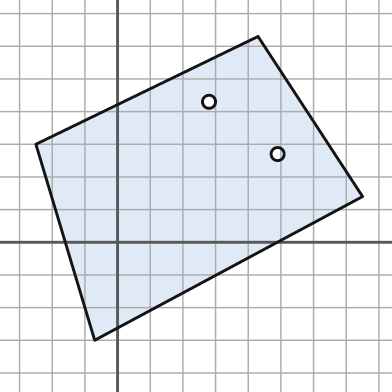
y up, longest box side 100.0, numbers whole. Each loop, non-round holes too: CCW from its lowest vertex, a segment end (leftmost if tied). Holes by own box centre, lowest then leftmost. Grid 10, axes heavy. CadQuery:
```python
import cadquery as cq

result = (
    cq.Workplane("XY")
    .moveTo(-7.0, -30.0)
    .lineTo(75.0, 14.0)
    .lineTo(43.0, 63.0)
    .lineTo(-25.0, 30.0)
    .close()
    .moveTo(49.0, 27.0)
    .circle(2.0)
    .moveTo(28.0, 43.0)
    .circle(2.0)
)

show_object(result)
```